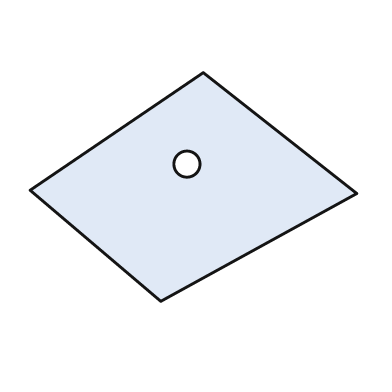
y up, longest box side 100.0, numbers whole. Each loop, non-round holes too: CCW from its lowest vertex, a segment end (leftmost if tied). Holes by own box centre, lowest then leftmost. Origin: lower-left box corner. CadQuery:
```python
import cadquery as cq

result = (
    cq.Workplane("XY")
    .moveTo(40.0, 0.0)
    .lineTo(100.0, 33.0)
    .lineTo(53.0, 70.0)
    .lineTo(0.0, 34.0)
    .close()
    .moveTo(48.0, 42.0)
    .circle(4.0)
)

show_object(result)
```